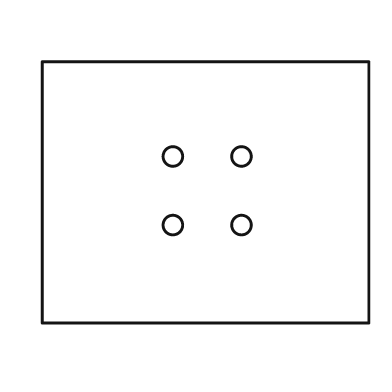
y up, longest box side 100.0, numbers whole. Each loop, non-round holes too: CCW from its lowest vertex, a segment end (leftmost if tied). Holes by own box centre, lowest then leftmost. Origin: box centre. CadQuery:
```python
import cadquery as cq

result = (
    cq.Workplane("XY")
    .moveTo(-50.0, -40.0)
    .lineTo(50.0, -40.0)
    .lineTo(50.0, 40.0)
    .lineTo(-50.0, 40.0)
    .close()
    .moveTo(-10.0, -10.0)
    .circle(3.0)
    .moveTo(11.0, -10.0)
    .circle(3.0)
    .moveTo(-10.0, 11.0)
    .circle(3.0)
    .moveTo(11.0, 11.0)
    .circle(3.0)
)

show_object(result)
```